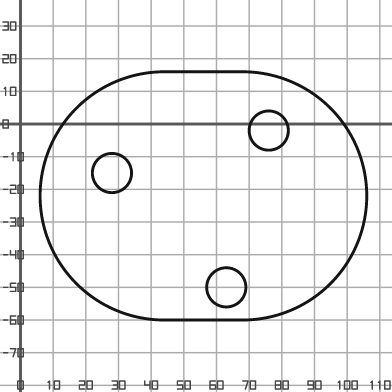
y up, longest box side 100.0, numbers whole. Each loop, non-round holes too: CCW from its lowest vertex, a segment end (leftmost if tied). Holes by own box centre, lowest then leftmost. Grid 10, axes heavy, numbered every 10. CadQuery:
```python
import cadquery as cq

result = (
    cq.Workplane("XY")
    .moveTo(44.0, -60.0)
    .lineTo(68.0, -60.0)
    .threePointArc((106.0, -22.0), (68.0, 16.0))
    .lineTo(44.0, 16.0)
    .threePointArc((6.0, -22.0), (44.0, -60.0))
    .close()
    .moveTo(63.0, -50.0)
    .circle(6.0)
    .moveTo(28.0, -15.0)
    .circle(6.0)
    .moveTo(76.0, -2.0)
    .circle(6.0)
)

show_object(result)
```